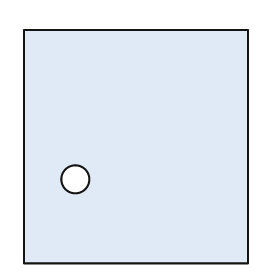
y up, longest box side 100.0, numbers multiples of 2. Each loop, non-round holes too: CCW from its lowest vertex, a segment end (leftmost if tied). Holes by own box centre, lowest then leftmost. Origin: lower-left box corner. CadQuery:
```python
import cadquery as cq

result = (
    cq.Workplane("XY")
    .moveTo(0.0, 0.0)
    .lineTo(96.0, 0.0)
    .lineTo(96.0, 100.0)
    .lineTo(0.0, 100.0)
    .close()
    .moveTo(22.0, 36.0)
    .circle(6.0)
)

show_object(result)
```